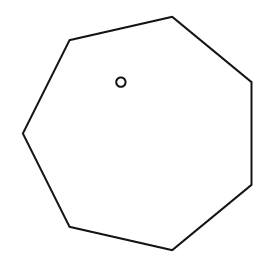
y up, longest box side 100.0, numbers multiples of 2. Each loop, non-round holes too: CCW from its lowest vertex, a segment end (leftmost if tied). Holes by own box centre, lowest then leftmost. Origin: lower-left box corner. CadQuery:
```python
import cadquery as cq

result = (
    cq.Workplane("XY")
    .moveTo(64.0, 0.0)
    .lineTo(98.0, 28.0)
    .lineTo(98.0, 72.0)
    .lineTo(64.0, 100.0)
    .lineTo(20.0, 90.0)
    .lineTo(0.0, 50.0)
    .lineTo(20.0, 10.0)
    .close()
    .moveTo(42.0, 72.0)
    .circle(2.0)
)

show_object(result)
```